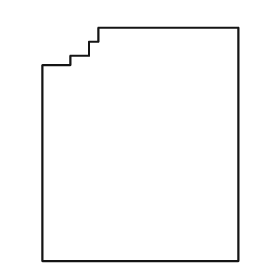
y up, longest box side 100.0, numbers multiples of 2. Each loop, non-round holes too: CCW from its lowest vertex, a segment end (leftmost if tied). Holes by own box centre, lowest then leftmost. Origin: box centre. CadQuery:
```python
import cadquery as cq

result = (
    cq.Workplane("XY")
    .moveTo(-42.0, -50.0)
    .lineTo(42.0, -50.0)
    .lineTo(42.0, 50.0)
    .lineTo(-18.0, 50.0)
    .lineTo(-18.0, 44.0)
    .lineTo(-22.0, 44.0)
    .lineTo(-22.0, 38.0)
    .lineTo(-30.0, 38.0)
    .lineTo(-30.0, 34.0)
    .lineTo(-42.0, 34.0)
    .close()
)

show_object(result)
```